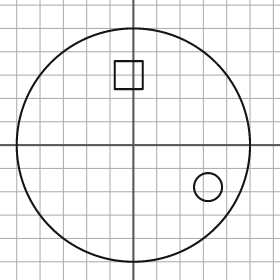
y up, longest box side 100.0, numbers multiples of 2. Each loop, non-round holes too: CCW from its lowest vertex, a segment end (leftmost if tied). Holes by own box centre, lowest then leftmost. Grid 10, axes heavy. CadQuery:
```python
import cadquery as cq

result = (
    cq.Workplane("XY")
    .moveTo(0.0, 0.0)
    .circle(50.0)
    .moveTo(32.0, -18.0)
    .circle(6.0)
    .moveTo(-8.0, 24.0)
    .lineTo(4.0, 24.0)
    .lineTo(4.0, 36.0)
    .lineTo(-8.0, 36.0)
    .close()
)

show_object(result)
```